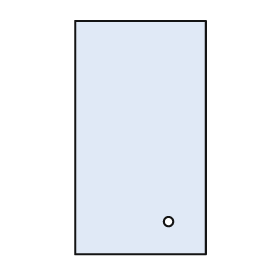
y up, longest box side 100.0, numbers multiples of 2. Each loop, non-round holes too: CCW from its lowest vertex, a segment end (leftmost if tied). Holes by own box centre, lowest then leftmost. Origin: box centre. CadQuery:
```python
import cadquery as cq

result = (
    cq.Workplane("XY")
    .moveTo(-28.0, -50.0)
    .lineTo(28.0, -50.0)
    .lineTo(28.0, 50.0)
    .lineTo(-28.0, 50.0)
    .close()
    .moveTo(12.0, -36.0)
    .circle(2.0)
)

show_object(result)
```